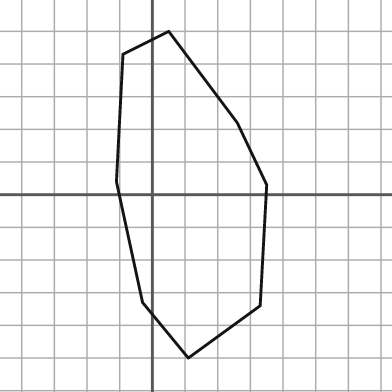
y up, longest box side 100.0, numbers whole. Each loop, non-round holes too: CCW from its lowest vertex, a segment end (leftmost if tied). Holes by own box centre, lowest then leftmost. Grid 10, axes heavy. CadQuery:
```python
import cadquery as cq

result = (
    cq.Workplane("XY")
    .moveTo(11.0, -50.0)
    .lineTo(33.0, -34.0)
    .lineTo(35.0, 3.0)
    .lineTo(26.0, 22.0)
    .lineTo(5.0, 50.0)
    .lineTo(-9.0, 43.0)
    .lineTo(-11.0, 4.0)
    .lineTo(-3.0, -33.0)
    .close()
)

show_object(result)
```